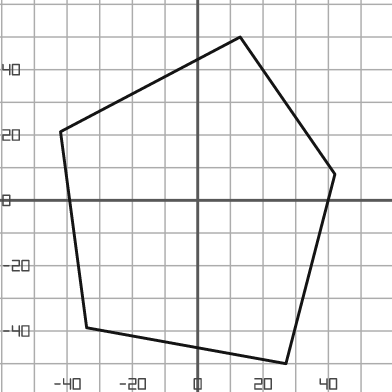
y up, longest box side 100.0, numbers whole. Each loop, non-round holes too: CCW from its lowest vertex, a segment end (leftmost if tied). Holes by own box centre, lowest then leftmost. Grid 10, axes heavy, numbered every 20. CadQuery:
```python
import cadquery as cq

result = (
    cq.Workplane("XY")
    .moveTo(27.0, -50.0)
    .lineTo(42.0, 8.0)
    .lineTo(13.0, 50.0)
    .lineTo(-42.0, 21.0)
    .lineTo(-34.0, -39.0)
    .close()
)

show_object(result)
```